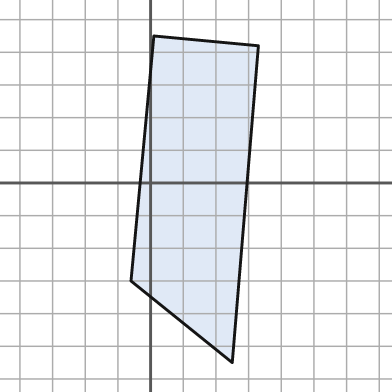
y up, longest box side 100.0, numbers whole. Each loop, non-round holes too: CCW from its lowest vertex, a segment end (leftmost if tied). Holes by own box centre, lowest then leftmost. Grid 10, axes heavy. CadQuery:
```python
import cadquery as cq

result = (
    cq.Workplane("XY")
    .moveTo(25.0, -55.0)
    .lineTo(33.0, 42.0)
    .lineTo(1.0, 45.0)
    .lineTo(-6.0, -30.0)
    .close()
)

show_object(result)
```